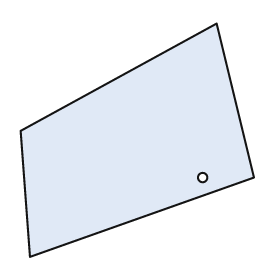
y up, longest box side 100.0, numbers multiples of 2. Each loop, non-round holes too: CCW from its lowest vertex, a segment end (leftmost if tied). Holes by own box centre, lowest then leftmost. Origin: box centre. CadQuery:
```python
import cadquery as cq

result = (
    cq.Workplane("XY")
    .moveTo(-46.0, -50.0)
    .lineTo(50.0, -16.0)
    .lineTo(34.0, 50.0)
    .lineTo(-50.0, 4.0)
    .close()
    .moveTo(28.0, -16.0)
    .circle(2.0)
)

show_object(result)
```